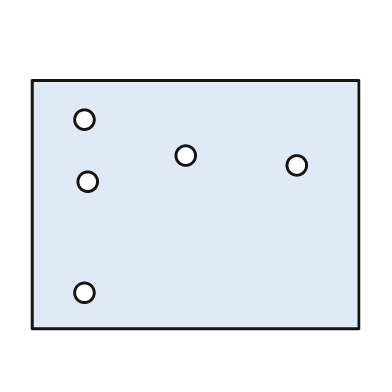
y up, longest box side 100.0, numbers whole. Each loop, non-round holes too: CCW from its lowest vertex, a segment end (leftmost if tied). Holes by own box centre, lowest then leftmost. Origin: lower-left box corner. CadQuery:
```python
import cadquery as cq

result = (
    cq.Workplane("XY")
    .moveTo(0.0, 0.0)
    .lineTo(100.0, 0.0)
    .lineTo(100.0, 76.0)
    .lineTo(0.0, 76.0)
    .close()
    .moveTo(16.0, 11.0)
    .circle(3.0)
    .moveTo(17.0, 45.0)
    .circle(3.0)
    .moveTo(81.0, 50.0)
    .circle(3.0)
    .moveTo(47.0, 53.0)
    .circle(3.0)
    .moveTo(16.0, 64.0)
    .circle(3.0)
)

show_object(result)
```